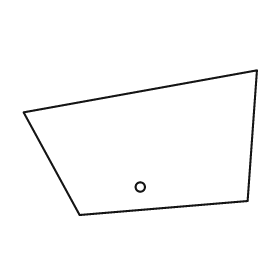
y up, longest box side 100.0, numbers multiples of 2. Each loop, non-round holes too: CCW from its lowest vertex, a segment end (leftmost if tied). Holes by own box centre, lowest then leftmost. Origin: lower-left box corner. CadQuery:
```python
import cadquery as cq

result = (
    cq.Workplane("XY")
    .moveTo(24.0, 0.0)
    .lineTo(96.0, 6.0)
    .lineTo(100.0, 62.0)
    .lineTo(0.0, 44.0)
    .close()
    .moveTo(50.0, 12.0)
    .circle(2.0)
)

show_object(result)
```